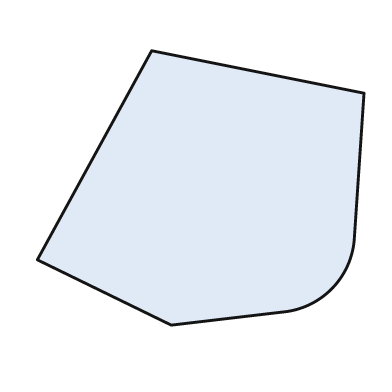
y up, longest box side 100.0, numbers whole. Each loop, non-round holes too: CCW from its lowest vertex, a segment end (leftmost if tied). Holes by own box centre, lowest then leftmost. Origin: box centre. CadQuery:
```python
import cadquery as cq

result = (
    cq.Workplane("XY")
    .moveTo(-9.0, -42.0)
    .lineTo(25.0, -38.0)
    .threePointArc((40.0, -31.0), (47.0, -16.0))
    .lineTo(50.0, 29.0)
    .lineTo(-15.0, 42.0)
    .lineTo(-50.0, -22.0)
    .close()
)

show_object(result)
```